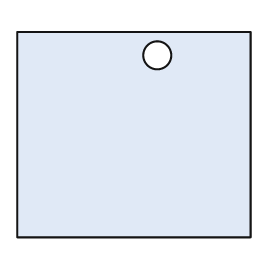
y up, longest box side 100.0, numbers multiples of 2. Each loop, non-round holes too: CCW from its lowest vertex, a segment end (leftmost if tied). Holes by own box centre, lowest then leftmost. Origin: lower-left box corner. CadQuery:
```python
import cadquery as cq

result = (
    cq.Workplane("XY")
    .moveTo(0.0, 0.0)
    .lineTo(100.0, 0.0)
    .lineTo(100.0, 88.0)
    .lineTo(0.0, 88.0)
    .close()
    .moveTo(60.0, 78.0)
    .circle(6.0)
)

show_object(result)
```